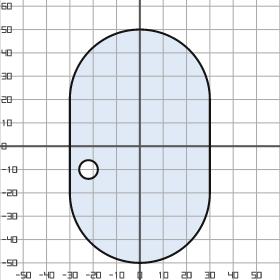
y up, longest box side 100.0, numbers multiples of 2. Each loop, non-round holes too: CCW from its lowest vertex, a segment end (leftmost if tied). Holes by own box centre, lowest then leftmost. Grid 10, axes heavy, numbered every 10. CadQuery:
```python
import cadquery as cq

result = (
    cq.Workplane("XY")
    .moveTo(-30.0, -20.0)
    .threePointArc((0.0, -50.0), (30.0, -20.0))
    .lineTo(30.0, 20.0)
    .threePointArc((0.0, 50.0), (-30.0, 20.0))
    .close()
    .moveTo(-22.0, -10.0)
    .circle(4.0)
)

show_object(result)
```